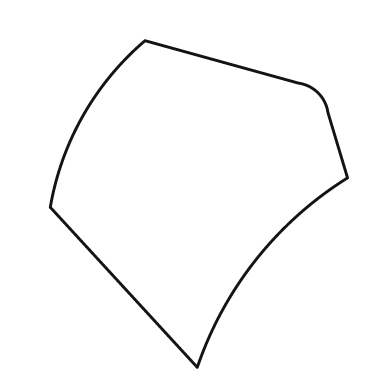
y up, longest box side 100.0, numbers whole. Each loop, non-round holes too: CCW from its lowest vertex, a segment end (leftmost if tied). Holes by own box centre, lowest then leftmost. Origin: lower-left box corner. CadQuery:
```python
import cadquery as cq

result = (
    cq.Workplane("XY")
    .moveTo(45.0, 0.0)
    .threePointArc((63.0, 33.0), (91.0, 58.0))
    .lineTo(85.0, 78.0)
    .threePointArc((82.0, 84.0), (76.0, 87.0))
    .lineTo(29.0, 100.0)
    .threePointArc((10.0, 77.0), (0.0, 49.0))
    .close()
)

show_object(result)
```